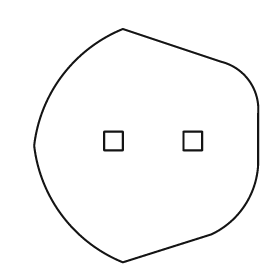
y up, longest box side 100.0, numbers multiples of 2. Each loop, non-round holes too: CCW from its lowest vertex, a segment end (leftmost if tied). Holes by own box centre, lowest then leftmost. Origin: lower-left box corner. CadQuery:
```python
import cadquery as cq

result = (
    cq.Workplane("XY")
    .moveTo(38.0, 0.0)
    .lineTo(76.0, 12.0)
    .threePointArc((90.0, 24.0), (96.0, 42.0))
    .lineTo(96.0, 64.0)
    .threePointArc((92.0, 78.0), (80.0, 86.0))
    .lineTo(38.0, 100.0)
    .threePointArc((12.0, 80.0), (0.0, 50.0))
    .threePointArc((12.0, 20.0), (38.0, 0.0))
    .close()
    .moveTo(30.0, 48.0)
    .lineTo(38.0, 48.0)
    .lineTo(38.0, 56.0)
    .lineTo(30.0, 56.0)
    .close()
    .moveTo(64.0, 48.0)
    .lineTo(72.0, 48.0)
    .lineTo(72.0, 56.0)
    .lineTo(64.0, 56.0)
    .close()
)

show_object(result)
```